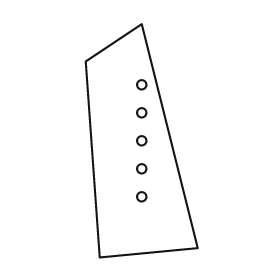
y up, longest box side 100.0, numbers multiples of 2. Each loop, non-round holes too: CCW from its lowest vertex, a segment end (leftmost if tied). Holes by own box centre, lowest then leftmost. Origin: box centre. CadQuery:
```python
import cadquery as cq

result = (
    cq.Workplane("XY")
    .moveTo(-18.0, -50.0)
    .lineTo(24.0, -46.0)
    .lineTo(0.0, 50.0)
    .lineTo(-24.0, 34.0)
    .close()
    .moveTo(0.0, -24.0)
    .circle(2.0)
    .moveTo(0.0, -12.0)
    .circle(2.0)
    .moveTo(0.0, 0.0)
    .circle(2.0)
    .moveTo(0.0, 12.0)
    .circle(2.0)
    .moveTo(0.0, 24.0)
    .circle(2.0)
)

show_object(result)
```